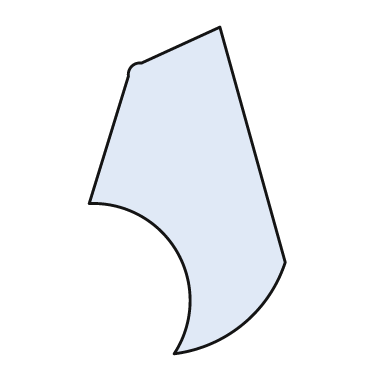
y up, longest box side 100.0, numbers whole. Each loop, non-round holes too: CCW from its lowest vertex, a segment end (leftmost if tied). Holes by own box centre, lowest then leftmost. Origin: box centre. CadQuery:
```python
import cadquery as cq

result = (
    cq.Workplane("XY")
    .moveTo(-4.0, -50.0)
    .threePointArc((17.0, -41.0), (30.0, -22.0))
    .lineTo(10.0, 50.0)
    .lineTo(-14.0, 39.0)
    .threePointArc((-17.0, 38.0), (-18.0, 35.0))
    .lineTo(-30.0, -4.0)
    .threePointArc((-3.0, -19.0), (-4.0, -50.0))
    .close()
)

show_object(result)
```